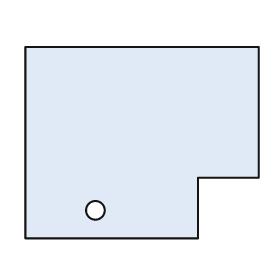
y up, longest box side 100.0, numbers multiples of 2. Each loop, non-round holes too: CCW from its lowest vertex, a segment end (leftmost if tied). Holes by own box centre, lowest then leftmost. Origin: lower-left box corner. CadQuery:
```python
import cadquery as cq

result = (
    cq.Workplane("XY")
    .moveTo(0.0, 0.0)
    .lineTo(74.0, 0.0)
    .lineTo(74.0, 26.0)
    .lineTo(100.0, 26.0)
    .lineTo(100.0, 82.0)
    .lineTo(0.0, 82.0)
    .close()
    .moveTo(30.0, 12.0)
    .circle(4.0)
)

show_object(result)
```